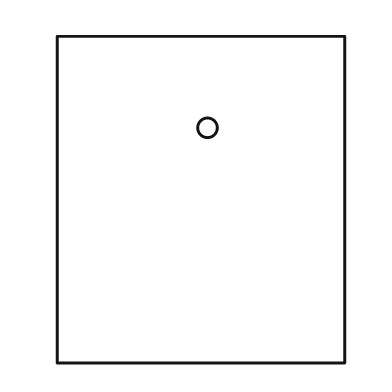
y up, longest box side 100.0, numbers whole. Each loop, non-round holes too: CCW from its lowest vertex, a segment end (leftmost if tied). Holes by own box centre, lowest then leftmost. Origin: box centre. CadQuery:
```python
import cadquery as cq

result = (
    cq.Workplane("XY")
    .moveTo(-44.0, -50.0)
    .lineTo(44.0, -50.0)
    .lineTo(44.0, 50.0)
    .lineTo(-44.0, 50.0)
    .close()
    .moveTo(2.0, 22.0)
    .circle(3.0)
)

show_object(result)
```